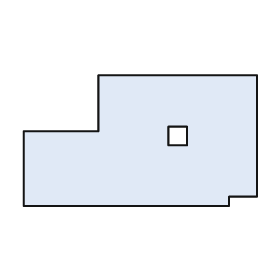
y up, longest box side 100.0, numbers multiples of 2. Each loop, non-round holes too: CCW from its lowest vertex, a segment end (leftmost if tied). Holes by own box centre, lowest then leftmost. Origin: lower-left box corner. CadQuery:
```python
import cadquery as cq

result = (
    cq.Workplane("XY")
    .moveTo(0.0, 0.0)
    .lineTo(88.0, 0.0)
    .lineTo(88.0, 4.0)
    .lineTo(100.0, 4.0)
    .lineTo(100.0, 56.0)
    .lineTo(32.0, 56.0)
    .lineTo(32.0, 32.0)
    .lineTo(0.0, 32.0)
    .close()
    .moveTo(62.0, 26.0)
    .lineTo(70.0, 26.0)
    .lineTo(70.0, 34.0)
    .lineTo(62.0, 34.0)
    .close()
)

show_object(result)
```